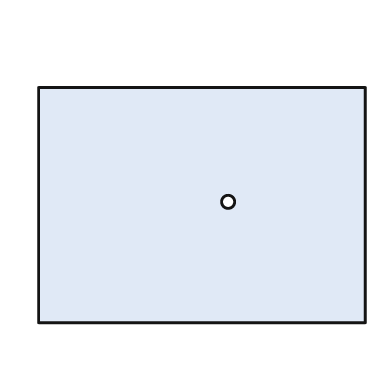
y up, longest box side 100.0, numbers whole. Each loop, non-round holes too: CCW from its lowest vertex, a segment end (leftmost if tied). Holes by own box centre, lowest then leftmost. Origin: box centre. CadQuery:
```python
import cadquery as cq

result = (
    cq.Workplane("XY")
    .moveTo(-50.0, -36.0)
    .lineTo(50.0, -36.0)
    .lineTo(50.0, 36.0)
    .lineTo(-50.0, 36.0)
    .close()
    .moveTo(8.0, 1.0)
    .circle(2.0)
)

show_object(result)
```